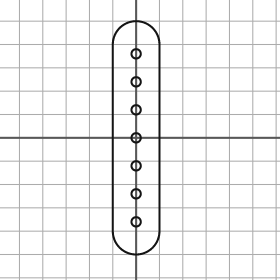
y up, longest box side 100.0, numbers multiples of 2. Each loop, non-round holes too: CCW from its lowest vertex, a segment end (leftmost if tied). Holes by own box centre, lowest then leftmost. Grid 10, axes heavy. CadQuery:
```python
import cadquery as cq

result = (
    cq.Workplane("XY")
    .moveTo(-10.0, -40.0)
    .threePointArc((0.0, -50.0), (10.0, -40.0))
    .lineTo(10.0, 40.0)
    .threePointArc((0.0, 50.0), (-10.0, 40.0))
    .close()
    .moveTo(0.0, -36.0)
    .circle(2.0)
    .moveTo(0.0, -24.0)
    .circle(2.0)
    .moveTo(0.0, -12.0)
    .circle(2.0)
    .moveTo(0.0, 0.0)
    .circle(2.0)
    .moveTo(0.0, 12.0)
    .circle(2.0)
    .moveTo(0.0, 24.0)
    .circle(2.0)
    .moveTo(0.0, 36.0)
    .circle(2.0)
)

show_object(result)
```